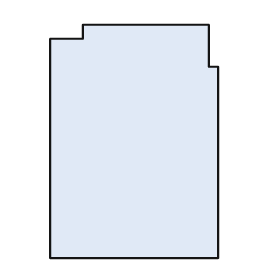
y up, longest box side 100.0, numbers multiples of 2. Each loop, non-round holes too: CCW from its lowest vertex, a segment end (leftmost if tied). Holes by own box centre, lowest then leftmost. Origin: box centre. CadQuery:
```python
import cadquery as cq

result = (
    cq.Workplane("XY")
    .moveTo(-36.0, -50.0)
    .lineTo(36.0, -50.0)
    .lineTo(36.0, 32.0)
    .lineTo(32.0, 32.0)
    .lineTo(32.0, 50.0)
    .lineTo(-22.0, 50.0)
    .lineTo(-22.0, 44.0)
    .lineTo(-36.0, 44.0)
    .close()
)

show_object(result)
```